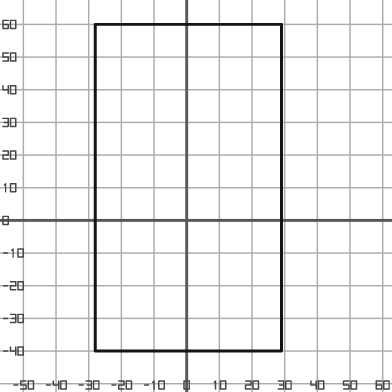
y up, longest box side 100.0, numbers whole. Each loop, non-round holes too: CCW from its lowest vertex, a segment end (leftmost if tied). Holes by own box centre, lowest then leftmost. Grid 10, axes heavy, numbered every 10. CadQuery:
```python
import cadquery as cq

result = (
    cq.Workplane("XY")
    .moveTo(-28.0, -40.0)
    .lineTo(29.0, -40.0)
    .lineTo(29.0, 60.0)
    .lineTo(-28.0, 60.0)
    .close()
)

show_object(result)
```